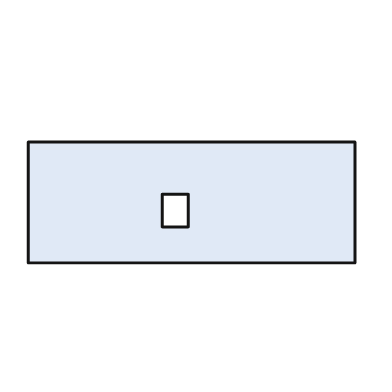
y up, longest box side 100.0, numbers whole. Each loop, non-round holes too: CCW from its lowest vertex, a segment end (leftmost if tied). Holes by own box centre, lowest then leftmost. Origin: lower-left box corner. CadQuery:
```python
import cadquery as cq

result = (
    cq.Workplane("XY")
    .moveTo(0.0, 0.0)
    .lineTo(100.0, 0.0)
    .lineTo(100.0, 37.0)
    .lineTo(0.0, 37.0)
    .close()
    .moveTo(41.0, 11.0)
    .lineTo(49.0, 11.0)
    .lineTo(49.0, 21.0)
    .lineTo(41.0, 21.0)
    .close()
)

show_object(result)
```